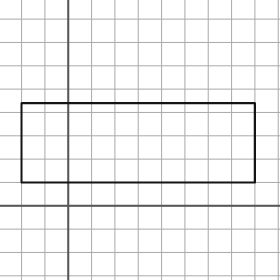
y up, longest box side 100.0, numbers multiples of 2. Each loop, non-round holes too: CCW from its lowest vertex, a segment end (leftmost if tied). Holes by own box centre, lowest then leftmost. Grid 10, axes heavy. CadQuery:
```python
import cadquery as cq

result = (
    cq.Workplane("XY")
    .moveTo(-20.0, 10.0)
    .lineTo(80.0, 10.0)
    .lineTo(80.0, 44.0)
    .lineTo(-20.0, 44.0)
    .close()
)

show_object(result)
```